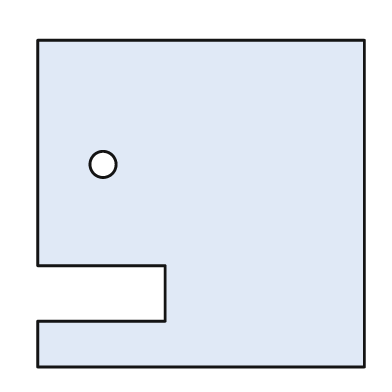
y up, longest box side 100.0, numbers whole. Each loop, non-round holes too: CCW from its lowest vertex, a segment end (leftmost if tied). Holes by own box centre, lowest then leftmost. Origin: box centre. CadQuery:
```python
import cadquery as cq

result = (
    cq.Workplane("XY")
    .moveTo(-50.0, -50.0)
    .lineTo(50.0, -50.0)
    .lineTo(50.0, 50.0)
    .lineTo(-50.0, 50.0)
    .lineTo(-50.0, -19.0)
    .lineTo(-11.0, -19.0)
    .lineTo(-11.0, -36.0)
    .lineTo(-50.0, -36.0)
    .close()
    .moveTo(-30.0, 12.0)
    .circle(4.0)
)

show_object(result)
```